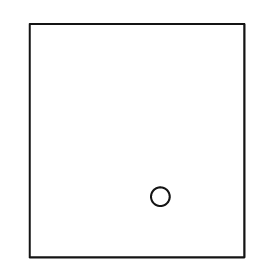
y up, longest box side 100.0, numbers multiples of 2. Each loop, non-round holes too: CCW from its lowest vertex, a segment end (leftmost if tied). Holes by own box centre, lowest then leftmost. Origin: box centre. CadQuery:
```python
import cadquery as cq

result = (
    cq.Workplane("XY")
    .moveTo(-46.0, -50.0)
    .lineTo(46.0, -50.0)
    .lineTo(46.0, 50.0)
    .lineTo(-46.0, 50.0)
    .close()
    .moveTo(10.0, -24.0)
    .circle(4.0)
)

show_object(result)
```